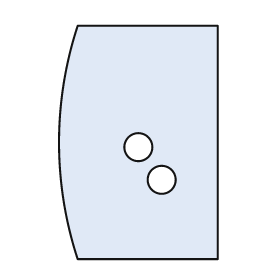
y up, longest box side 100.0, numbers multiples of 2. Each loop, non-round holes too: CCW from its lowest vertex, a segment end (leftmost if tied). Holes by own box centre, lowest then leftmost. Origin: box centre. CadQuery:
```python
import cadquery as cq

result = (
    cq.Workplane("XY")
    .moveTo(-26.0, -50.0)
    .lineTo(34.0, -50.0)
    .lineTo(34.0, 50.0)
    .lineTo(-26.0, 50.0)
    .threePointArc((-34.0, 0.0), (-26.0, -50.0))
    .close()
    .moveTo(10.0, -16.0)
    .circle(6.0)
    .moveTo(0.0, -2.0)
    .circle(6.0)
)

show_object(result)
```